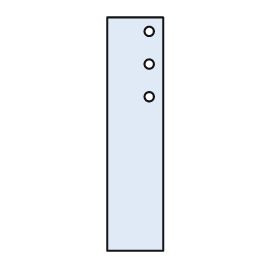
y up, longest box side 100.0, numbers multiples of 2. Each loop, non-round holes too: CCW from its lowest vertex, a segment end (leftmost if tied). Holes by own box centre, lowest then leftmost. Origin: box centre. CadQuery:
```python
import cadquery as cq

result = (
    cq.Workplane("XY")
    .moveTo(-12.0, -50.0)
    .lineTo(12.0, -50.0)
    .lineTo(12.0, 50.0)
    .lineTo(-12.0, 50.0)
    .close()
    .moveTo(6.0, 16.0)
    .circle(2.0)
    .moveTo(6.0, 30.0)
    .circle(2.0)
    .moveTo(6.0, 44.0)
    .circle(2.0)
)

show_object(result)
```